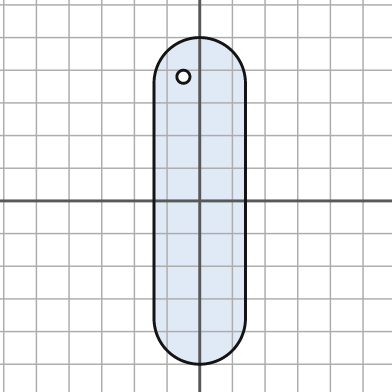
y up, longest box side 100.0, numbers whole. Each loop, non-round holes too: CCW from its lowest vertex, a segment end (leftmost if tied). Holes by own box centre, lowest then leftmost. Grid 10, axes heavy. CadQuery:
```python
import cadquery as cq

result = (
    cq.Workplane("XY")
    .moveTo(-14.0, -36.0)
    .threePointArc((0.0, -50.0), (14.0, -36.0))
    .lineTo(14.0, 36.0)
    .threePointArc((0.0, 50.0), (-14.0, 36.0))
    .close()
    .moveTo(-5.0, 38.0)
    .circle(2.0)
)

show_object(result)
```